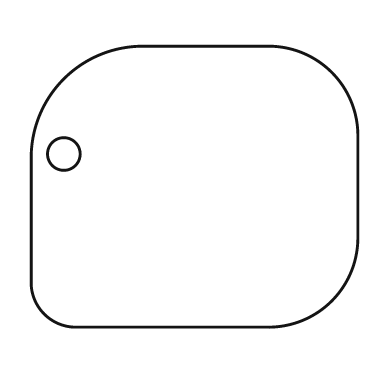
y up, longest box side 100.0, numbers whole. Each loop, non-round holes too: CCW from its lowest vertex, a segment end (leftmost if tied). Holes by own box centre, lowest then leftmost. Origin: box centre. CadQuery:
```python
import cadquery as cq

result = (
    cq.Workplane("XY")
    .moveTo(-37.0, -43.0)
    .lineTo(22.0, -43.0)
    .threePointArc((42.0, -35.0), (50.0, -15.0))
    .lineTo(50.0, 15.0)
    .threePointArc((42.0, 35.0), (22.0, 43.0))
    .lineTo(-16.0, 43.0)
    .threePointArc((-40.0, 33.0), (-50.0, 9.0))
    .lineTo(-50.0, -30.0)
    .threePointArc((-46.0, -39.0), (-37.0, -43.0))
    .close()
    .moveTo(-40.0, 10.0)
    .circle(5.0)
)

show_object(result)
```